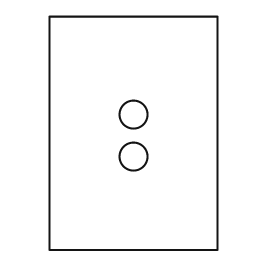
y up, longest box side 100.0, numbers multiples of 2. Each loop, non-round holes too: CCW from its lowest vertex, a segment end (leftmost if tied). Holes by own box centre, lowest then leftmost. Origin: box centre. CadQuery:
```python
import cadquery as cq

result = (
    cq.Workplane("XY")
    .moveTo(-36.0, -50.0)
    .lineTo(36.0, -50.0)
    .lineTo(36.0, 50.0)
    .lineTo(-36.0, 50.0)
    .close()
    .moveTo(0.0, -10.0)
    .circle(6.0)
    .moveTo(0.0, 8.0)
    .circle(6.0)
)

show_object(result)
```